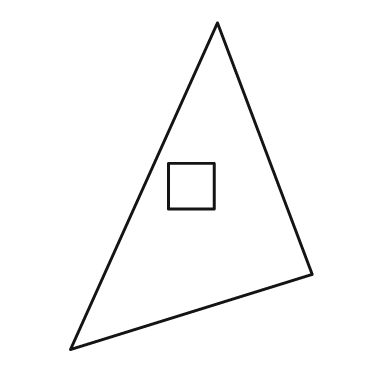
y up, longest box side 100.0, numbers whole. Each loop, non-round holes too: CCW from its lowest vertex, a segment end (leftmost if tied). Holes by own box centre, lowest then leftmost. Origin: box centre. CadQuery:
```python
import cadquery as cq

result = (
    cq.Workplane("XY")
    .moveTo(-37.0, -50.0)
    .lineTo(37.0, -27.0)
    .lineTo(8.0, 50.0)
    .close()
    .moveTo(-7.0, -7.0)
    .lineTo(7.0, -7.0)
    .lineTo(7.0, 7.0)
    .lineTo(-7.0, 7.0)
    .close()
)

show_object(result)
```